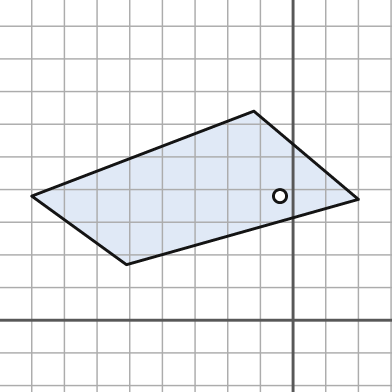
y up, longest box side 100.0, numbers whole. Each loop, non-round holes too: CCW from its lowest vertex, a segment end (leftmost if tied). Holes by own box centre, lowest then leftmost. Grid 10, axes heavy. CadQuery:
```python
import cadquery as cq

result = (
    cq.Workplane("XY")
    .moveTo(-51.0, 17.0)
    .lineTo(20.0, 37.0)
    .lineTo(-12.0, 64.0)
    .lineTo(-80.0, 38.0)
    .close()
    .moveTo(-4.0, 38.0)
    .circle(2.0)
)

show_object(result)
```